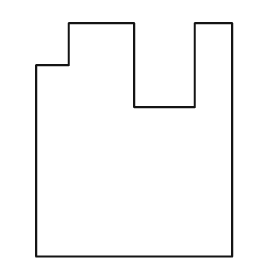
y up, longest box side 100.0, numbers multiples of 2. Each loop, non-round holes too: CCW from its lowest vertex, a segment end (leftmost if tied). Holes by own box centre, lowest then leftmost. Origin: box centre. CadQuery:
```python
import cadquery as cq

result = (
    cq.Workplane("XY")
    .moveTo(-42.0, -50.0)
    .lineTo(42.0, -50.0)
    .lineTo(42.0, 50.0)
    .lineTo(26.0, 50.0)
    .lineTo(26.0, 14.0)
    .lineTo(0.0, 14.0)
    .lineTo(0.0, 50.0)
    .lineTo(-28.0, 50.0)
    .lineTo(-28.0, 32.0)
    .lineTo(-42.0, 32.0)
    .close()
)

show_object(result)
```